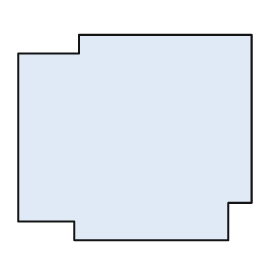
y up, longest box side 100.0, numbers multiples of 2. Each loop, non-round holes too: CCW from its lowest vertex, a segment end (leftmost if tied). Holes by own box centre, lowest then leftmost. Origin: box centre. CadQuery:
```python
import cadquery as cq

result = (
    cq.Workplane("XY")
    .moveTo(-26.0, -44.0)
    .lineTo(40.0, -44.0)
    .lineTo(40.0, -28.0)
    .lineTo(50.0, -28.0)
    .lineTo(50.0, 44.0)
    .lineTo(-24.0, 44.0)
    .lineTo(-24.0, 36.0)
    .lineTo(-50.0, 36.0)
    .lineTo(-50.0, -36.0)
    .lineTo(-26.0, -36.0)
    .close()
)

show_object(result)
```